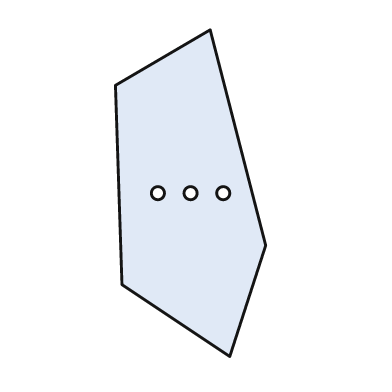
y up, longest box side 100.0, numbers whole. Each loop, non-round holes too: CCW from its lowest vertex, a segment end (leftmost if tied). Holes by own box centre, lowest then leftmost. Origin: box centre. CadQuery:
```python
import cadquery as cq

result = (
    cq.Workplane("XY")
    .moveTo(12.0, -50.0)
    .lineTo(23.0, -16.0)
    .lineTo(6.0, 50.0)
    .lineTo(-23.0, 33.0)
    .lineTo(-21.0, -28.0)
    .close()
    .moveTo(-10.0, 0.0)
    .circle(2.0)
    .moveTo(0.0, 0.0)
    .circle(2.0)
    .moveTo(10.0, 0.0)
    .circle(2.0)
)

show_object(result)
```